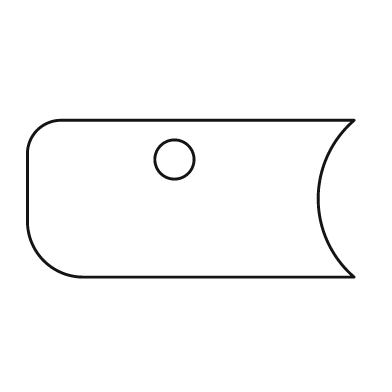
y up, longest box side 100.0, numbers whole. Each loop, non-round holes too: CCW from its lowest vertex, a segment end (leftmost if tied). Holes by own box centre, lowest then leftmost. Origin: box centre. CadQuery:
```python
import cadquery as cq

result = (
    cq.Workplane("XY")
    .moveTo(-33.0, -24.0)
    .lineTo(50.0, -24.0)
    .threePointArc((39.0, 0.0), (50.0, 24.0))
    .lineTo(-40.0, 24.0)
    .threePointArc((-47.0, 21.0), (-50.0, 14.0))
    .lineTo(-50.0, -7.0)
    .threePointArc((-45.0, -19.0), (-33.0, -24.0))
    .close()
    .moveTo(-5.0, 12.0)
    .circle(6.0)
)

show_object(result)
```